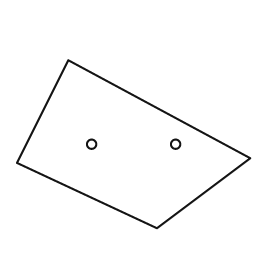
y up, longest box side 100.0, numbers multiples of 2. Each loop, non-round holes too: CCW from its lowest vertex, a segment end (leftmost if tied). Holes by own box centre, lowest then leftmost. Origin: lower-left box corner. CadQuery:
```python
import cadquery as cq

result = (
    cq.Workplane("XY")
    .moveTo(60.0, 0.0)
    .lineTo(100.0, 30.0)
    .lineTo(22.0, 72.0)
    .lineTo(0.0, 28.0)
    .close()
    .moveTo(32.0, 36.0)
    .circle(2.0)
    .moveTo(68.0, 36.0)
    .circle(2.0)
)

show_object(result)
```